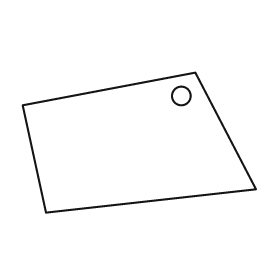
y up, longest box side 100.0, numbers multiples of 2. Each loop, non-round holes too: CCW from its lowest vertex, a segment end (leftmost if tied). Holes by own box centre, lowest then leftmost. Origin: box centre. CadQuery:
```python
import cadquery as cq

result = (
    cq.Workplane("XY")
    .moveTo(-40.0, -30.0)
    .lineTo(50.0, -20.0)
    .lineTo(24.0, 30.0)
    .lineTo(-50.0, 16.0)
    .close()
    .moveTo(18.0, 20.0)
    .circle(4.0)
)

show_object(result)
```